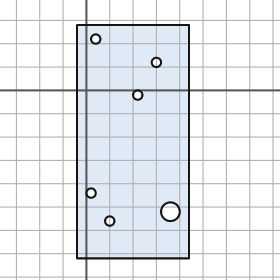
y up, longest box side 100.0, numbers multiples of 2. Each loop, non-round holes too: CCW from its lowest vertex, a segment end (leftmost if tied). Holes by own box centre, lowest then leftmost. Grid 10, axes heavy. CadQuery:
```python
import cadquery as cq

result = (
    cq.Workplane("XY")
    .moveTo(-4.0, -72.0)
    .lineTo(44.0, -72.0)
    .lineTo(44.0, 28.0)
    .lineTo(-4.0, 28.0)
    .close()
    .moveTo(10.0, -56.0)
    .circle(2.0)
    .moveTo(36.0, -52.0)
    .circle(4.0)
    .moveTo(2.0, -44.0)
    .circle(2.0)
    .moveTo(22.0, -2.0)
    .circle(2.0)
    .moveTo(30.0, 12.0)
    .circle(2.0)
    .moveTo(4.0, 22.0)
    .circle(2.0)
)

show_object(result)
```